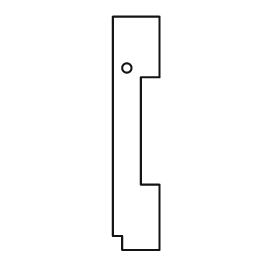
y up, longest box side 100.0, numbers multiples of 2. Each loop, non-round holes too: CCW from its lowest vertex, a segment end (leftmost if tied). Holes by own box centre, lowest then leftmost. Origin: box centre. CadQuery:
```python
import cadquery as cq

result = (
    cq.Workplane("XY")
    .moveTo(-6.0, -50.0)
    .lineTo(10.0, -50.0)
    .lineTo(10.0, -22.0)
    .lineTo(2.0, -22.0)
    .lineTo(2.0, 24.0)
    .lineTo(10.0, 24.0)
    .lineTo(10.0, 50.0)
    .lineTo(-10.0, 50.0)
    .lineTo(-10.0, -44.0)
    .lineTo(-6.0, -44.0)
    .close()
    .moveTo(-4.0, 28.0)
    .circle(2.0)
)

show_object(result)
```